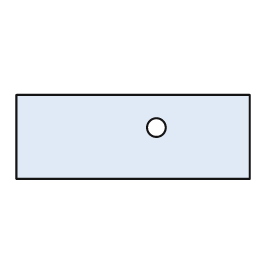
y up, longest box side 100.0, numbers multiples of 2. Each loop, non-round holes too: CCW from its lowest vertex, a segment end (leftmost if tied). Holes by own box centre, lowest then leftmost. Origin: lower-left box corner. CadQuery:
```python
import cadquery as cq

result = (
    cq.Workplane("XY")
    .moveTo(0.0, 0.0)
    .lineTo(100.0, 0.0)
    .lineTo(100.0, 36.0)
    .lineTo(0.0, 36.0)
    .close()
    .moveTo(60.0, 22.0)
    .circle(4.0)
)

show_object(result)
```